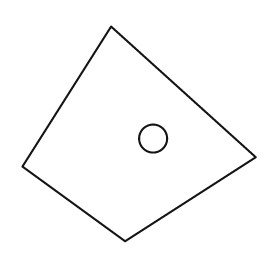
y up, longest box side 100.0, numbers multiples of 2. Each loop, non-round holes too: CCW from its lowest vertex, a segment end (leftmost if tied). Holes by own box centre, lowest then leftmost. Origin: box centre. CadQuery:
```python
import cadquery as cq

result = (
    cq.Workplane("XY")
    .moveTo(-6.0, -46.0)
    .lineTo(50.0, -10.0)
    .lineTo(-12.0, 46.0)
    .lineTo(-50.0, -14.0)
    .close()
    .moveTo(6.0, -2.0)
    .circle(6.0)
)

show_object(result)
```